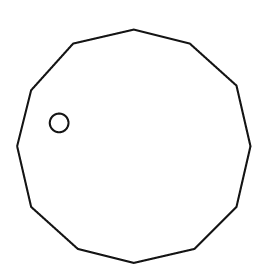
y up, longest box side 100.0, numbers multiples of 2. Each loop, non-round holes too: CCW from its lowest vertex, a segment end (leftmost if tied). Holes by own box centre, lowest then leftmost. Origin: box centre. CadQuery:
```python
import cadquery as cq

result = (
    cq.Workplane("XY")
    .moveTo(0.0, -50.0)
    .lineTo(26.0, -44.0)
    .lineTo(44.0, -26.0)
    .lineTo(50.0, 0.0)
    .lineTo(44.0, 26.0)
    .lineTo(24.0, 44.0)
    .lineTo(0.0, 50.0)
    .lineTo(-26.0, 44.0)
    .lineTo(-44.0, 24.0)
    .lineTo(-50.0, 0.0)
    .lineTo(-44.0, -26.0)
    .lineTo(-24.0, -44.0)
    .close()
    .moveTo(-32.0, 10.0)
    .circle(4.0)
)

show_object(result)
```